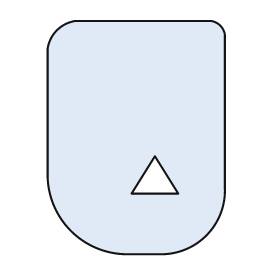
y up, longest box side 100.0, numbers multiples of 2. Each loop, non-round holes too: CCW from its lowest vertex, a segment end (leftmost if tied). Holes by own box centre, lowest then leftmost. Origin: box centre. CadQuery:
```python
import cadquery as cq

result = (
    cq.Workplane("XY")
    .moveTo(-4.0, -50.0)
    .lineTo(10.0, -50.0)
    .threePointArc((30.0, -42.0), (38.0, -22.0))
    .lineTo(38.0, 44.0)
    .threePointArc((36.0, 48.0), (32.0, 50.0))
    .lineTo(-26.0, 50.0)
    .threePointArc((-34.0, 46.0), (-38.0, 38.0))
    .lineTo(-38.0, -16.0)
    .threePointArc((-28.0, -40.0), (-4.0, -50.0))
    .close()
    .moveTo(-2.0, -24.0)
    .lineTo(18.0, -24.0)
    .lineTo(8.0, -8.0)
    .close()
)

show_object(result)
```